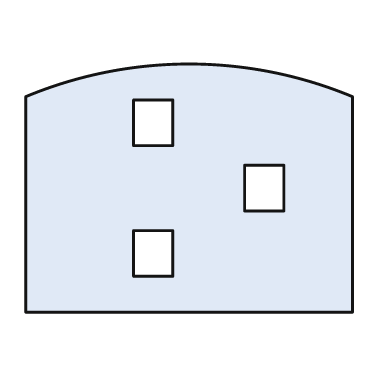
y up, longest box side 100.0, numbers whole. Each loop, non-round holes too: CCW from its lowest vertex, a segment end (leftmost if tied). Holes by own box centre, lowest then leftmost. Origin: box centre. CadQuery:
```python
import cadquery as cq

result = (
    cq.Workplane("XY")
    .moveTo(-50.0, -38.0)
    .lineTo(50.0, -38.0)
    .lineTo(50.0, 28.0)
    .threePointArc((0.0, 38.0), (-50.0, 28.0))
    .close()
    .moveTo(-17.0, -27.0)
    .lineTo(-5.0, -27.0)
    .lineTo(-5.0, -13.0)
    .lineTo(-17.0, -13.0)
    .close()
    .moveTo(17.0, -7.0)
    .lineTo(29.0, -7.0)
    .lineTo(29.0, 7.0)
    .lineTo(17.0, 7.0)
    .close()
    .moveTo(-17.0, 13.0)
    .lineTo(-5.0, 13.0)
    .lineTo(-5.0, 27.0)
    .lineTo(-17.0, 27.0)
    .close()
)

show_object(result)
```